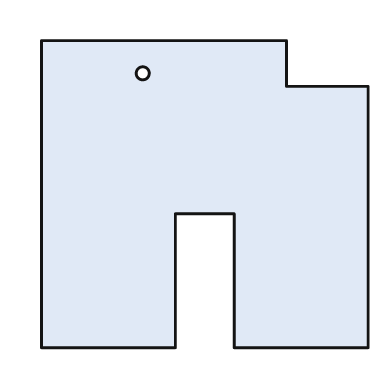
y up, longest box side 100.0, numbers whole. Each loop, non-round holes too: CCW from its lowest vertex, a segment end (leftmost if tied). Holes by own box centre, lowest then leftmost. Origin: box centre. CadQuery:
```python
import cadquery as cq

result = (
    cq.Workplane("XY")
    .moveTo(-50.0, -47.0)
    .lineTo(-9.0, -47.0)
    .lineTo(-9.0, -6.0)
    .lineTo(9.0, -6.0)
    .lineTo(9.0, -47.0)
    .lineTo(50.0, -47.0)
    .lineTo(50.0, 33.0)
    .lineTo(25.0, 33.0)
    .lineTo(25.0, 47.0)
    .lineTo(-50.0, 47.0)
    .close()
    .moveTo(-19.0, 37.0)
    .circle(2.0)
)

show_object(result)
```